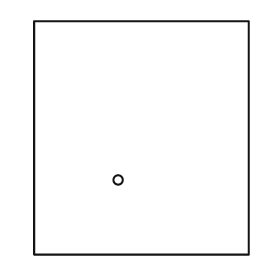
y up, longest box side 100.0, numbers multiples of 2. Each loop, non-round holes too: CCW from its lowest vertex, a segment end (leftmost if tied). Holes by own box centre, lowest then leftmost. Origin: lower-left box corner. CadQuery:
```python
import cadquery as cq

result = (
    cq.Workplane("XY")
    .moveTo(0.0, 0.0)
    .lineTo(92.0, 0.0)
    .lineTo(92.0, 100.0)
    .lineTo(0.0, 100.0)
    .close()
    .moveTo(36.0, 32.0)
    .circle(2.0)
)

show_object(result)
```